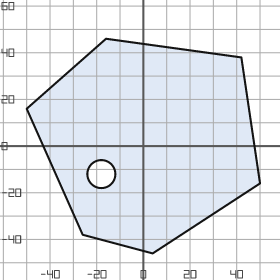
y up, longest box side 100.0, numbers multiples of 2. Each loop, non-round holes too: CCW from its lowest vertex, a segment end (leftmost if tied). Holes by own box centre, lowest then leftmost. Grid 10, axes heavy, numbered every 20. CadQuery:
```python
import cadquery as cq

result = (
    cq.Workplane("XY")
    .moveTo(4.0, -46.0)
    .lineTo(50.0, -16.0)
    .lineTo(42.0, 38.0)
    .lineTo(-16.0, 46.0)
    .lineTo(-50.0, 16.0)
    .lineTo(-26.0, -38.0)
    .close()
    .moveTo(-18.0, -12.0)
    .circle(6.0)
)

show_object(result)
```